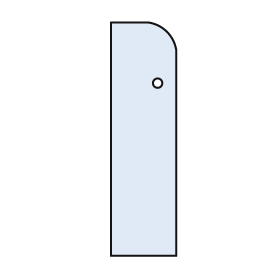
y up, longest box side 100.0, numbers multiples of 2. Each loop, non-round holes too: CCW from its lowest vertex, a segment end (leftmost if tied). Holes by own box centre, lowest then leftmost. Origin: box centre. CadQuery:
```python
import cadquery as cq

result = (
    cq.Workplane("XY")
    .moveTo(-14.0, -50.0)
    .lineTo(14.0, -50.0)
    .lineTo(14.0, 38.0)
    .threePointArc((10.0, 46.0), (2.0, 50.0))
    .lineTo(-14.0, 50.0)
    .close()
    .moveTo(6.0, 24.0)
    .circle(2.0)
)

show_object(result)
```